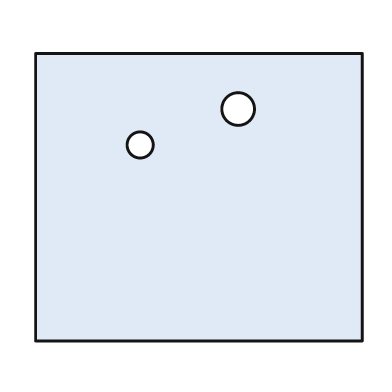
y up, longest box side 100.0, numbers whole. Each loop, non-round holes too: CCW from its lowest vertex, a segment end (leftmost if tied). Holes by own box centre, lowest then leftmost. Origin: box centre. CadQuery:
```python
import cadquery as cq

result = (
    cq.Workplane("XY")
    .moveTo(-50.0, -44.0)
    .lineTo(50.0, -44.0)
    .lineTo(50.0, 44.0)
    .lineTo(-50.0, 44.0)
    .close()
    .moveTo(-18.0, 16.0)
    .circle(4.0)
    .moveTo(12.0, 27.0)
    .circle(5.0)
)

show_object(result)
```